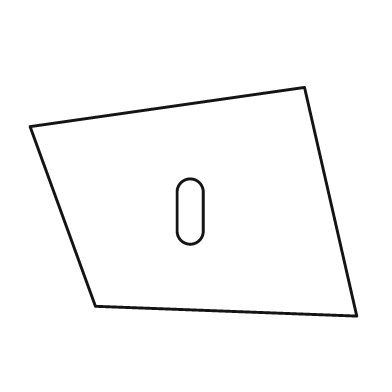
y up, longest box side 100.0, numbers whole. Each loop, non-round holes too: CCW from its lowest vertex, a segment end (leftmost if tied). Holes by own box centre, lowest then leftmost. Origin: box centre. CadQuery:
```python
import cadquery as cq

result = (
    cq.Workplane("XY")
    .moveTo(50.0, -35.0)
    .lineTo(34.0, 35.0)
    .lineTo(-50.0, 23.0)
    .lineTo(-30.0, -32.0)
    .close()
    .moveTo(-5.0, -9.0)
    .threePointArc((-1.0, -13.0), (3.0, -9.0))
    .lineTo(3.0, 3.0)
    .threePointArc((-1.0, 7.0), (-5.0, 3.0))
    .close()
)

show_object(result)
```